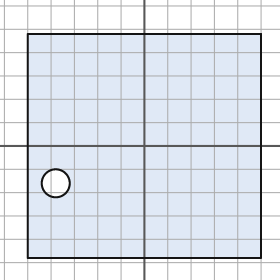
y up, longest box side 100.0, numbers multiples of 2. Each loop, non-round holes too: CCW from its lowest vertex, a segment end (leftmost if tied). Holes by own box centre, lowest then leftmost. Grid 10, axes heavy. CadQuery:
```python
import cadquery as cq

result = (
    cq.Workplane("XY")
    .moveTo(-50.0, -48.0)
    .lineTo(50.0, -48.0)
    .lineTo(50.0, 48.0)
    .lineTo(-50.0, 48.0)
    .close()
    .moveTo(-38.0, -16.0)
    .circle(6.0)
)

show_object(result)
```